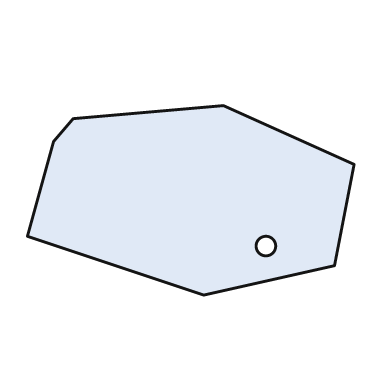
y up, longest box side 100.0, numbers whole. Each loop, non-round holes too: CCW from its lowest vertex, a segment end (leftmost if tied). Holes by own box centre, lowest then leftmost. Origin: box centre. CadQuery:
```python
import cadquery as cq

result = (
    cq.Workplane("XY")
    .moveTo(4.0, -29.0)
    .lineTo(44.0, -20.0)
    .lineTo(50.0, 11.0)
    .lineTo(10.0, 29.0)
    .lineTo(-36.0, 25.0)
    .lineTo(-42.0, 18.0)
    .lineTo(-50.0, -11.0)
    .close()
    .moveTo(23.0, -14.0)
    .circle(3.0)
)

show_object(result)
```